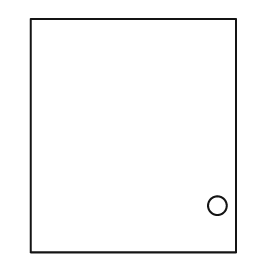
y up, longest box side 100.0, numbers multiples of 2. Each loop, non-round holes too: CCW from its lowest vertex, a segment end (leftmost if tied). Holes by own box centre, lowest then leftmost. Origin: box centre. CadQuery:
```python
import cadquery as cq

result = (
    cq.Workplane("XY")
    .moveTo(-44.0, -50.0)
    .lineTo(44.0, -50.0)
    .lineTo(44.0, 50.0)
    .lineTo(-44.0, 50.0)
    .close()
    .moveTo(36.0, -30.0)
    .circle(4.0)
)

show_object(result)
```